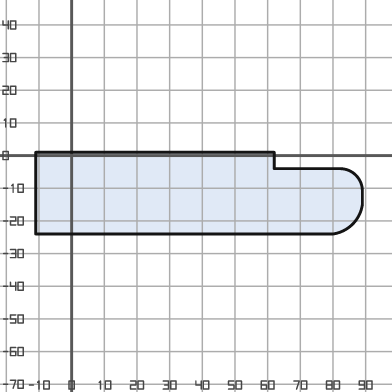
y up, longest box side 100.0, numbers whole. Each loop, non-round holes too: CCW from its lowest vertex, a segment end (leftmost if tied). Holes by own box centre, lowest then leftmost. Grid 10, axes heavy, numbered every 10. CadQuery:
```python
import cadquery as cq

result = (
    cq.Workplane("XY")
    .moveTo(-11.0, -24.0)
    .lineTo(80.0, -24.0)
    .threePointArc((86.0, -21.0), (89.0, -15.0))
    .lineTo(89.0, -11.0)
    .threePointArc((87.0, -6.0), (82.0, -4.0))
    .lineTo(62.0, -4.0)
    .lineTo(62.0, 1.0)
    .lineTo(-11.0, 1.0)
    .close()
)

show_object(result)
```